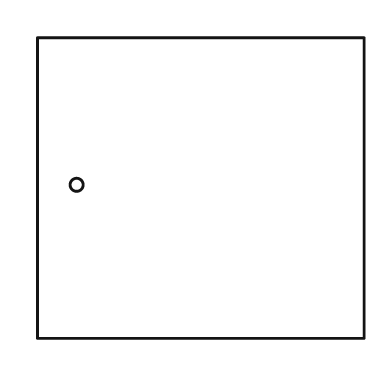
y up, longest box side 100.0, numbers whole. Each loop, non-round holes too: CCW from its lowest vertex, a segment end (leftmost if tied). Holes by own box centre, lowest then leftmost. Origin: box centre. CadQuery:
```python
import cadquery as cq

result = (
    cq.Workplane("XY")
    .moveTo(-50.0, -46.0)
    .lineTo(50.0, -46.0)
    .lineTo(50.0, 46.0)
    .lineTo(-50.0, 46.0)
    .close()
    .moveTo(-38.0, 1.0)
    .circle(2.0)
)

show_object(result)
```